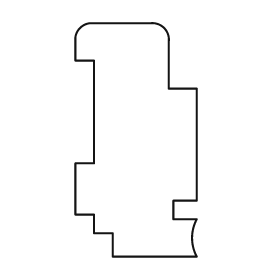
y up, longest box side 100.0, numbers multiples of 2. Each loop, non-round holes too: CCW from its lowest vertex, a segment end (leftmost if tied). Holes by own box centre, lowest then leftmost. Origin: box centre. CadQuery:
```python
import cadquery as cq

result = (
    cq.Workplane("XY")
    .moveTo(-10.0, -50.0)
    .lineTo(26.0, -50.0)
    .threePointArc((24.0, -42.0), (26.0, -34.0))
    .lineTo(16.0, -34.0)
    .lineTo(16.0, -26.0)
    .lineTo(26.0, -26.0)
    .lineTo(26.0, 22.0)
    .lineTo(14.0, 22.0)
    .lineTo(14.0, 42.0)
    .threePointArc((12.0, 48.0), (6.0, 50.0))
    .lineTo(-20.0, 50.0)
    .threePointArc((-24.0, 48.0), (-26.0, 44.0))
    .lineTo(-26.0, 34.0)
    .lineTo(-18.0, 34.0)
    .lineTo(-18.0, -10.0)
    .lineTo(-26.0, -10.0)
    .lineTo(-26.0, -32.0)
    .lineTo(-18.0, -32.0)
    .lineTo(-18.0, -40.0)
    .lineTo(-10.0, -40.0)
    .close()
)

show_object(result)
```